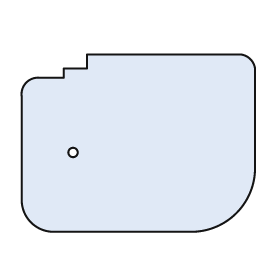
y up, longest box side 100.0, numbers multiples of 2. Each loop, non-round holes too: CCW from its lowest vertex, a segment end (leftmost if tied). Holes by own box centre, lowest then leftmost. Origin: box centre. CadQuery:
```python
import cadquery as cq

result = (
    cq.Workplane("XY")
    .moveTo(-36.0, -38.0)
    .lineTo(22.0, -38.0)
    .threePointArc((42.0, -30.0), (50.0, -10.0))
    .lineTo(50.0, 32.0)
    .threePointArc((48.0, 36.0), (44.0, 38.0))
    .lineTo(-22.0, 38.0)
    .lineTo(-22.0, 32.0)
    .lineTo(-32.0, 32.0)
    .lineTo(-32.0, 28.0)
    .lineTo(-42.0, 28.0)
    .threePointArc((-48.0, 26.0), (-50.0, 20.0))
    .lineTo(-50.0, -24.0)
    .threePointArc((-46.0, -34.0), (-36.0, -38.0))
    .close()
    .moveTo(-28.0, -4.0)
    .circle(2.0)
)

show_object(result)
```